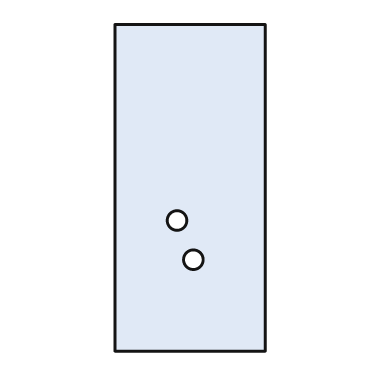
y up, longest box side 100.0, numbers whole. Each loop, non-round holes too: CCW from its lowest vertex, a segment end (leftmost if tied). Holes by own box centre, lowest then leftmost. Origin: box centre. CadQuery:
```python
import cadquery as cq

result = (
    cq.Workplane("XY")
    .moveTo(-23.0, -50.0)
    .lineTo(23.0, -50.0)
    .lineTo(23.0, 50.0)
    .lineTo(-23.0, 50.0)
    .close()
    .moveTo(1.0, -22.0)
    .circle(3.0)
    .moveTo(-4.0, -10.0)
    .circle(3.0)
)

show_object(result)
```